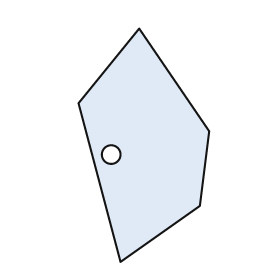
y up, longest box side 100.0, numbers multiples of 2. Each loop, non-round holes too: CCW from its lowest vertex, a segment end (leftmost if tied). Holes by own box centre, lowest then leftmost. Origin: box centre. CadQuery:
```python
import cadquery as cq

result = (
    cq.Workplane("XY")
    .moveTo(-10.0, -50.0)
    .lineTo(24.0, -26.0)
    .lineTo(28.0, 6.0)
    .lineTo(-2.0, 50.0)
    .lineTo(-28.0, 18.0)
    .close()
    .moveTo(-14.0, -4.0)
    .circle(4.0)
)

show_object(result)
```